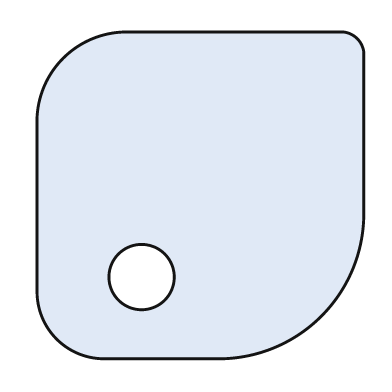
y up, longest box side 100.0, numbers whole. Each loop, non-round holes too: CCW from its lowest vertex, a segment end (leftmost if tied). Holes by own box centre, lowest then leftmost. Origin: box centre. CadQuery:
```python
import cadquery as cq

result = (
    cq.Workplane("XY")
    .moveTo(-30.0, -50.0)
    .lineTo(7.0, -50.0)
    .threePointArc((37.0, -37.0), (50.0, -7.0))
    .lineTo(50.0, 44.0)
    .threePointArc((48.0, 48.0), (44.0, 50.0))
    .lineTo(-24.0, 50.0)
    .threePointArc((-42.0, 42.0), (-50.0, 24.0))
    .lineTo(-50.0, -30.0)
    .threePointArc((-44.0, -44.0), (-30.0, -50.0))
    .close()
    .moveTo(-18.0, -25.0)
    .circle(10.0)
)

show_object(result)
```